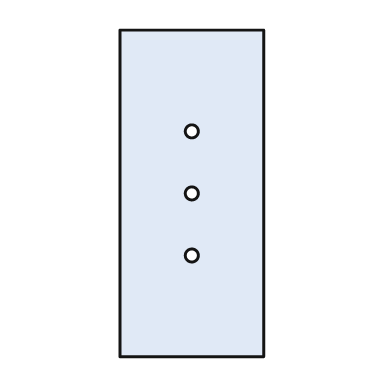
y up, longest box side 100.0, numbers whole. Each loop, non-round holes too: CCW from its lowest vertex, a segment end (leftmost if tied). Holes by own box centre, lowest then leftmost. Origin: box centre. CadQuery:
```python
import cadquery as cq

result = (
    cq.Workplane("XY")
    .moveTo(-22.0, -50.0)
    .lineTo(22.0, -50.0)
    .lineTo(22.0, 50.0)
    .lineTo(-22.0, 50.0)
    .close()
    .moveTo(0.0, -19.0)
    .circle(2.0)
    .moveTo(0.0, 0.0)
    .circle(2.0)
    .moveTo(0.0, 19.0)
    .circle(2.0)
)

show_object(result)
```